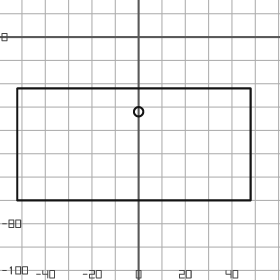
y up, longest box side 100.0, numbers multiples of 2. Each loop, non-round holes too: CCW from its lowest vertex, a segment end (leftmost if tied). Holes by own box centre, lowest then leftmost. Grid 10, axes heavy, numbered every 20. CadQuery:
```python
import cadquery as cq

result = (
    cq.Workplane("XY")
    .moveTo(-52.0, -70.0)
    .lineTo(48.0, -70.0)
    .lineTo(48.0, -22.0)
    .lineTo(-52.0, -22.0)
    .close()
    .moveTo(0.0, -32.0)
    .circle(2.0)
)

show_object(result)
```